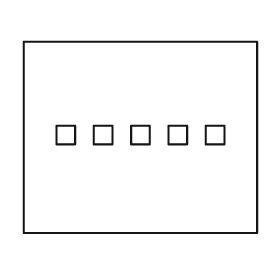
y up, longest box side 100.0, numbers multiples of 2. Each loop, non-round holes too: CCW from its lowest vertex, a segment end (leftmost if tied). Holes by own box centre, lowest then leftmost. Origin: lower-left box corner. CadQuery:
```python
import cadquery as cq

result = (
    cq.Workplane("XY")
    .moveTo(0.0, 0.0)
    .lineTo(100.0, 0.0)
    .lineTo(100.0, 82.0)
    .lineTo(0.0, 82.0)
    .close()
    .moveTo(14.0, 38.0)
    .lineTo(22.0, 38.0)
    .lineTo(22.0, 46.0)
    .lineTo(14.0, 46.0)
    .close()
    .moveTo(30.0, 38.0)
    .lineTo(38.0, 38.0)
    .lineTo(38.0, 46.0)
    .lineTo(30.0, 46.0)
    .close()
    .moveTo(46.0, 38.0)
    .lineTo(54.0, 38.0)
    .lineTo(54.0, 46.0)
    .lineTo(46.0, 46.0)
    .close()
    .moveTo(62.0, 38.0)
    .lineTo(70.0, 38.0)
    .lineTo(70.0, 46.0)
    .lineTo(62.0, 46.0)
    .close()
    .moveTo(78.0, 38.0)
    .lineTo(86.0, 38.0)
    .lineTo(86.0, 46.0)
    .lineTo(78.0, 46.0)
    .close()
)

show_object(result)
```